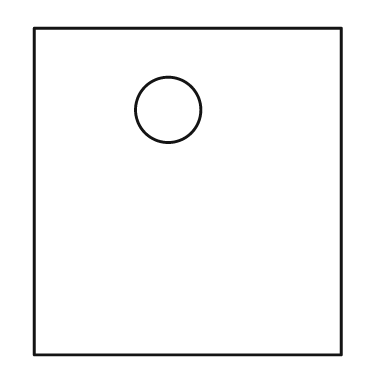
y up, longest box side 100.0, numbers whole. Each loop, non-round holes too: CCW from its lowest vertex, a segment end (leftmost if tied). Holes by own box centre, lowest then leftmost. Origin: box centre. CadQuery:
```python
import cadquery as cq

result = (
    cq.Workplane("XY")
    .moveTo(-47.0, -50.0)
    .lineTo(47.0, -50.0)
    .lineTo(47.0, 50.0)
    .lineTo(-47.0, 50.0)
    .close()
    .moveTo(-6.0, 25.0)
    .circle(10.0)
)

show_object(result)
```